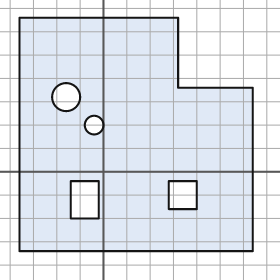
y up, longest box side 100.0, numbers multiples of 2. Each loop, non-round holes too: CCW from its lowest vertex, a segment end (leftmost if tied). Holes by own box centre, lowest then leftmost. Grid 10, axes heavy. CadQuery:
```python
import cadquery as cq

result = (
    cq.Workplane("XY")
    .moveTo(-36.0, -34.0)
    .lineTo(64.0, -34.0)
    .lineTo(64.0, 36.0)
    .lineTo(32.0, 36.0)
    .lineTo(32.0, 66.0)
    .lineTo(-36.0, 66.0)
    .close()
    .moveTo(-14.0, -20.0)
    .lineTo(-2.0, -20.0)
    .lineTo(-2.0, -4.0)
    .lineTo(-14.0, -4.0)
    .close()
    .moveTo(28.0, -16.0)
    .lineTo(40.0, -16.0)
    .lineTo(40.0, -4.0)
    .lineTo(28.0, -4.0)
    .close()
    .moveTo(-4.0, 20.0)
    .circle(4.0)
    .moveTo(-16.0, 32.0)
    .circle(6.0)
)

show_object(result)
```